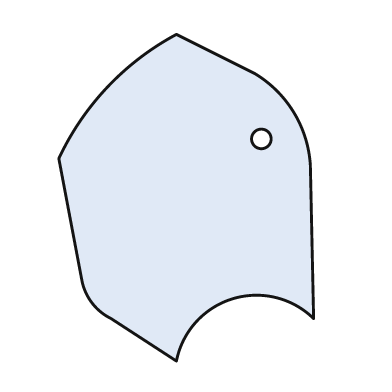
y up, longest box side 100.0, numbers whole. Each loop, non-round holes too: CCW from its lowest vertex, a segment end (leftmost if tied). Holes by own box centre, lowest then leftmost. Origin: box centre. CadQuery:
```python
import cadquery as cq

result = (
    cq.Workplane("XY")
    .moveTo(-3.0, -50.0)
    .threePointArc((14.0, -31.0), (39.0, -37.0))
    .lineTo(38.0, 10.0)
    .threePointArc((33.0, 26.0), (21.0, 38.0))
    .lineTo(-3.0, 50.0)
    .threePointArc((-24.0, 34.0), (-39.0, 12.0))
    .lineTo(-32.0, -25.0)
    .threePointArc((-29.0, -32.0), (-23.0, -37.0))
    .close()
    .moveTo(23.0, 18.0)
    .circle(3.0)
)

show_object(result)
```